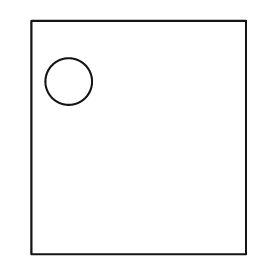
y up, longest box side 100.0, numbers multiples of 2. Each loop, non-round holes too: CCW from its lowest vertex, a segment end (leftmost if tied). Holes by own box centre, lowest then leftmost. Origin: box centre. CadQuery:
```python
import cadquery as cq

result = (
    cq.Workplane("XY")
    .moveTo(-46.0, -50.0)
    .lineTo(46.0, -50.0)
    .lineTo(46.0, 50.0)
    .lineTo(-46.0, 50.0)
    .close()
    .moveTo(-30.0, 24.0)
    .circle(10.0)
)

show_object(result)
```